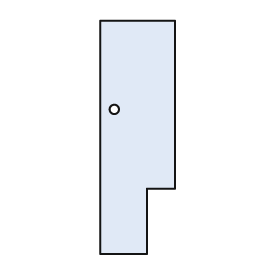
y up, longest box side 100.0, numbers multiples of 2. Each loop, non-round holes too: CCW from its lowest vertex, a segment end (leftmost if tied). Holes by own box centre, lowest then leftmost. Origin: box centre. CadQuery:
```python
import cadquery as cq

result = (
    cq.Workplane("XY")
    .moveTo(-16.0, -50.0)
    .lineTo(4.0, -50.0)
    .lineTo(4.0, -22.0)
    .lineTo(16.0, -22.0)
    .lineTo(16.0, 50.0)
    .lineTo(-16.0, 50.0)
    .close()
    .moveTo(-10.0, 12.0)
    .circle(2.0)
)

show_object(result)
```